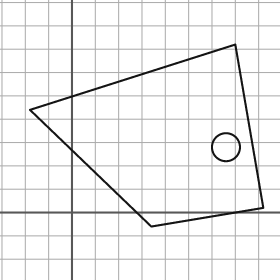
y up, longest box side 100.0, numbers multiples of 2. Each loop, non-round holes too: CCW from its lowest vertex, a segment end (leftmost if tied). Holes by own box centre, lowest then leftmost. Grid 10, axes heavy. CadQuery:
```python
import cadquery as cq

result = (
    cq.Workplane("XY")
    .moveTo(34.0, -6.0)
    .lineTo(82.0, 2.0)
    .lineTo(70.0, 72.0)
    .lineTo(-18.0, 44.0)
    .close()
    .moveTo(66.0, 28.0)
    .circle(6.0)
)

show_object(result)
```